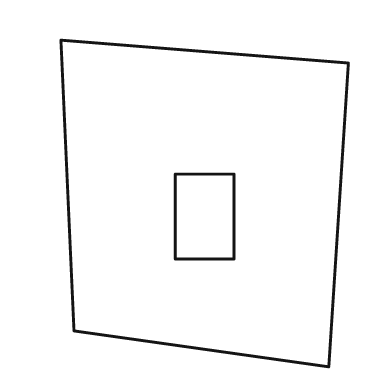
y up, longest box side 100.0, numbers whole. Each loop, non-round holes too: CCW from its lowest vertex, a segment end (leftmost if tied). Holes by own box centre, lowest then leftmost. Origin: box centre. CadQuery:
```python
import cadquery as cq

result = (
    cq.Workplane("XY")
    .moveTo(38.0, -50.0)
    .lineTo(44.0, 43.0)
    .lineTo(-44.0, 50.0)
    .lineTo(-40.0, -39.0)
    .close()
    .moveTo(-9.0, -17.0)
    .lineTo(9.0, -17.0)
    .lineTo(9.0, 9.0)
    .lineTo(-9.0, 9.0)
    .close()
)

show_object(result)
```